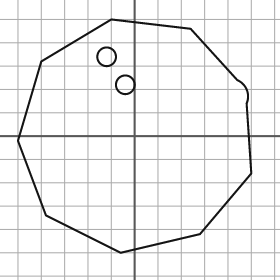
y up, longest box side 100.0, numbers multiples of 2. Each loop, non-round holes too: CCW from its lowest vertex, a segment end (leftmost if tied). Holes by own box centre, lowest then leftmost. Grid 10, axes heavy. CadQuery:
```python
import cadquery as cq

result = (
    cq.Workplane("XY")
    .moveTo(-6.0, -50.0)
    .lineTo(28.0, -42.0)
    .lineTo(50.0, -16.0)
    .lineTo(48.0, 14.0)
    .threePointArc((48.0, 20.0), (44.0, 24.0))
    .lineTo(24.0, 46.0)
    .lineTo(-10.0, 50.0)
    .lineTo(-40.0, 32.0)
    .lineTo(-50.0, -2.0)
    .lineTo(-38.0, -34.0)
    .close()
    .moveTo(-4.0, 22.0)
    .circle(4.0)
    .moveTo(-12.0, 34.0)
    .circle(4.0)
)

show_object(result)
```